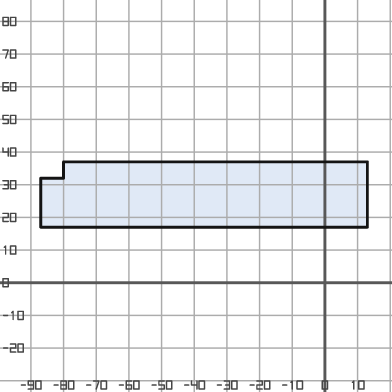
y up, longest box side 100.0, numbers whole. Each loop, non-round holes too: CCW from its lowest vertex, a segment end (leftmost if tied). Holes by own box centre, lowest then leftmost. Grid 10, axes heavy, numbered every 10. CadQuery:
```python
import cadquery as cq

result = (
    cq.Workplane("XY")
    .moveTo(-87.0, 17.0)
    .lineTo(13.0, 17.0)
    .lineTo(13.0, 37.0)
    .lineTo(-80.0, 37.0)
    .lineTo(-80.0, 32.0)
    .lineTo(-87.0, 32.0)
    .close()
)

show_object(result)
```